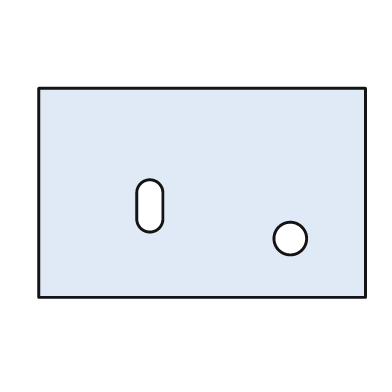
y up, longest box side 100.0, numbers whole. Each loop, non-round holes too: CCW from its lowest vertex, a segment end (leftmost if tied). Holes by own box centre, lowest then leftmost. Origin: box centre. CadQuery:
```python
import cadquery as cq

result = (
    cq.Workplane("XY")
    .moveTo(-50.0, -32.0)
    .lineTo(50.0, -32.0)
    .lineTo(50.0, 32.0)
    .lineTo(-50.0, 32.0)
    .close()
    .moveTo(27.0, -14.0)
    .circle(5.0)
    .moveTo(-20.0, -8.0)
    .threePointArc((-16.0, -12.0), (-12.0, -8.0))
    .lineTo(-12.0, 0.0)
    .threePointArc((-16.0, 4.0), (-20.0, 0.0))
    .close()
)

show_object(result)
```